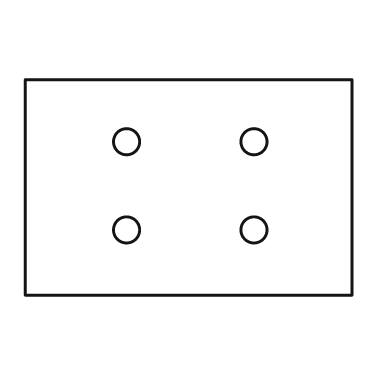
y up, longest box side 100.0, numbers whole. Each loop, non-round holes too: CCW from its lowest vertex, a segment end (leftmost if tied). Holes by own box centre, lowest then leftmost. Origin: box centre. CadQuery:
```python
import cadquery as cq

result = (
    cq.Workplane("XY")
    .moveTo(-50.0, -33.0)
    .lineTo(50.0, -33.0)
    .lineTo(50.0, 33.0)
    .lineTo(-50.0, 33.0)
    .close()
    .moveTo(-19.0, -13.0)
    .circle(4.0)
    .moveTo(20.0, -13.0)
    .circle(4.0)
    .moveTo(-19.0, 14.0)
    .circle(4.0)
    .moveTo(20.0, 14.0)
    .circle(4.0)
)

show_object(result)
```